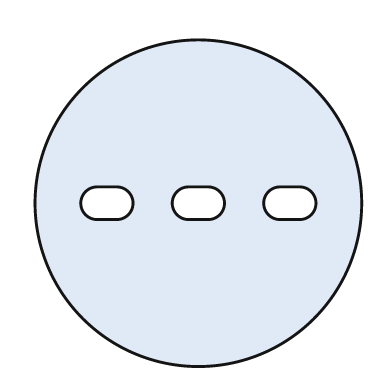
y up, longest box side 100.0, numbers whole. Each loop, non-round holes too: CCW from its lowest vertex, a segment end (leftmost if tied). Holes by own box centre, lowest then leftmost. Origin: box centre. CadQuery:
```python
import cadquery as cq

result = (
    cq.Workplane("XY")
    .moveTo(0.0, 0.0)
    .circle(50.0)
    .moveTo(-31.0, -5.0)
    .lineTo(-25.0, -5.0)
    .threePointArc((-20.0, 0.0), (-25.0, 5.0))
    .lineTo(-31.0, 5.0)
    .threePointArc((-36.0, 0.0), (-31.0, -5.0))
    .close()
    .moveTo(-3.0, -5.0)
    .lineTo(3.0, -5.0)
    .threePointArc((8.0, 0.0), (3.0, 5.0))
    .lineTo(-3.0, 5.0)
    .threePointArc((-8.0, 0.0), (-3.0, -5.0))
    .close()
    .moveTo(25.0, -5.0)
    .lineTo(31.0, -5.0)
    .threePointArc((36.0, 0.0), (31.0, 5.0))
    .lineTo(25.0, 5.0)
    .threePointArc((20.0, 0.0), (25.0, -5.0))
    .close()
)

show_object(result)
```